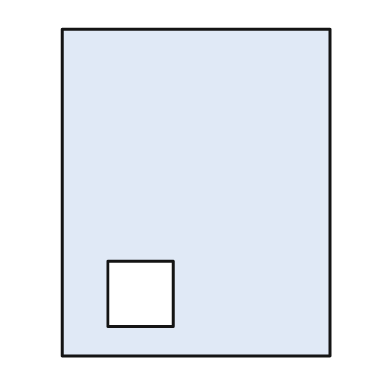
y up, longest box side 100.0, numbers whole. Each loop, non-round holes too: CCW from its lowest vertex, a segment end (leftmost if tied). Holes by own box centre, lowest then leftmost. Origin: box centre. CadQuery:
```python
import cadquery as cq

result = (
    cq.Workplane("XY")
    .moveTo(-41.0, -50.0)
    .lineTo(41.0, -50.0)
    .lineTo(41.0, 50.0)
    .lineTo(-41.0, 50.0)
    .close()
    .moveTo(-27.0, -41.0)
    .lineTo(-7.0, -41.0)
    .lineTo(-7.0, -21.0)
    .lineTo(-27.0, -21.0)
    .close()
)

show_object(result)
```